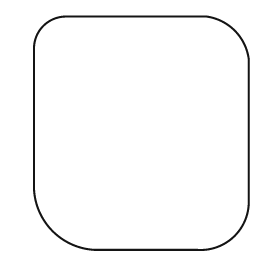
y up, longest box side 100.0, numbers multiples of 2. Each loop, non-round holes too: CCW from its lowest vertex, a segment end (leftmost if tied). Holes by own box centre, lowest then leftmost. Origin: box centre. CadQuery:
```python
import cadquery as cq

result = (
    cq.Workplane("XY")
    .moveTo(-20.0, -50.0)
    .lineTo(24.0, -50.0)
    .threePointArc((40.0, -44.0), (46.0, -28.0))
    .lineTo(46.0, 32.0)
    .threePointArc((40.0, 44.0), (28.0, 50.0))
    .lineTo(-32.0, 50.0)
    .threePointArc((-42.0, 46.0), (-46.0, 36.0))
    .lineTo(-46.0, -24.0)
    .threePointArc((-38.0, -42.0), (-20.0, -50.0))
    .close()
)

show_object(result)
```